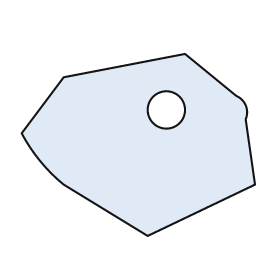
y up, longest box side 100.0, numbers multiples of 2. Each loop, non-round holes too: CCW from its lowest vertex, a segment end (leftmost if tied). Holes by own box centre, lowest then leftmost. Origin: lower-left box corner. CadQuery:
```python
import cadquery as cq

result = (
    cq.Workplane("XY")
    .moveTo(54.0, 0.0)
    .lineTo(100.0, 22.0)
    .lineTo(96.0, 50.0)
    .threePointArc((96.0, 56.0), (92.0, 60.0))
    .lineTo(70.0, 78.0)
    .lineTo(18.0, 68.0)
    .lineTo(0.0, 44.0)
    .threePointArc((8.0, 32.0), (18.0, 22.0))
    .close()
    .moveTo(62.0, 54.0)
    .circle(8.0)
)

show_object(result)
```